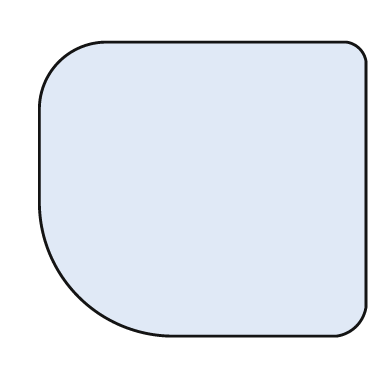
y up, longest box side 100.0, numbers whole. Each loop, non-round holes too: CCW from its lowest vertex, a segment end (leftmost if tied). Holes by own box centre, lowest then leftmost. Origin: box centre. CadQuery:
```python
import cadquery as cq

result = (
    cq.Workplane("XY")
    .moveTo(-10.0, -45.0)
    .lineTo(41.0, -45.0)
    .threePointArc((47.0, -42.0), (50.0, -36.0))
    .lineTo(50.0, 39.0)
    .threePointArc((48.0, 43.0), (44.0, 45.0))
    .lineTo(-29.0, 45.0)
    .threePointArc((-44.0, 39.0), (-50.0, 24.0))
    .lineTo(-50.0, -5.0)
    .threePointArc((-38.0, -33.0), (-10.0, -45.0))
    .close()
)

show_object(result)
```